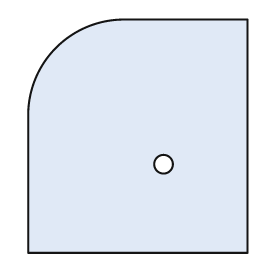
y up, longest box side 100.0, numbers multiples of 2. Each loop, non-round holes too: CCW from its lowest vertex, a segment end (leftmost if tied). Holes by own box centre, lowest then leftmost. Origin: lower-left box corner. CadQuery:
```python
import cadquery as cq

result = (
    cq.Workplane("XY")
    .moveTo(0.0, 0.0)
    .lineTo(94.0, 0.0)
    .lineTo(94.0, 100.0)
    .lineTo(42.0, 100.0)
    .threePointArc((12.0, 88.0), (0.0, 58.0))
    .close()
    .moveTo(58.0, 38.0)
    .circle(4.0)
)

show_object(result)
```